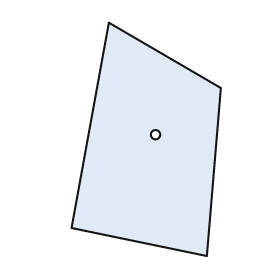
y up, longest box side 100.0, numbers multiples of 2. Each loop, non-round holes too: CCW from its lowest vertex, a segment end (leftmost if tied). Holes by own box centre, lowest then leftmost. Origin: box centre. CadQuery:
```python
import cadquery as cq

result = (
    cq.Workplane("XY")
    .moveTo(26.0, -50.0)
    .lineTo(32.0, 22.0)
    .lineTo(-16.0, 50.0)
    .lineTo(-32.0, -38.0)
    .close()
    .moveTo(4.0, 2.0)
    .circle(2.0)
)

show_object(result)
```